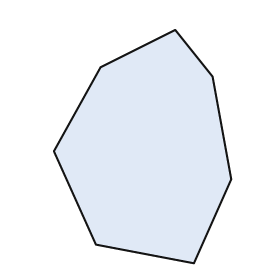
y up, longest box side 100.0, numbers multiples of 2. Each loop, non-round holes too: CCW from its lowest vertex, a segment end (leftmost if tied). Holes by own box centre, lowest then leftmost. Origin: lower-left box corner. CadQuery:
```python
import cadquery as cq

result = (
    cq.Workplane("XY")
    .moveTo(60.0, 0.0)
    .lineTo(76.0, 36.0)
    .lineTo(68.0, 80.0)
    .lineTo(52.0, 100.0)
    .lineTo(20.0, 84.0)
    .lineTo(0.0, 48.0)
    .lineTo(18.0, 8.0)
    .close()
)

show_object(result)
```